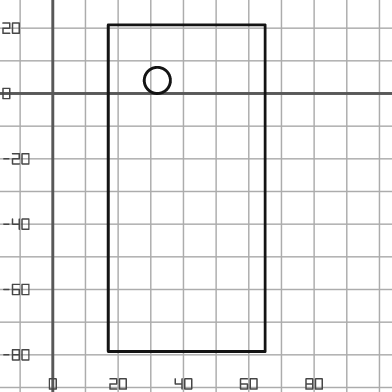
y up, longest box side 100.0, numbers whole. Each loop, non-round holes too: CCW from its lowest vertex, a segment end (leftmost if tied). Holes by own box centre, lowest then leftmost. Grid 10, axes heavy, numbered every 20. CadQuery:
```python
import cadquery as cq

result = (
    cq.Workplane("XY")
    .moveTo(17.0, -79.0)
    .lineTo(65.0, -79.0)
    .lineTo(65.0, 21.0)
    .lineTo(17.0, 21.0)
    .close()
    .moveTo(32.0, 4.0)
    .circle(4.0)
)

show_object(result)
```